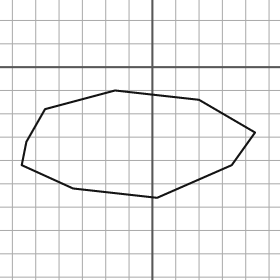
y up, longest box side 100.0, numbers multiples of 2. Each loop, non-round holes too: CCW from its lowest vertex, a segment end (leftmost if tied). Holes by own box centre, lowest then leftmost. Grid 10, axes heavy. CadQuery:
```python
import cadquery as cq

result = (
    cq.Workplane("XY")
    .moveTo(2.0, -56.0)
    .lineTo(34.0, -42.0)
    .lineTo(44.0, -28.0)
    .lineTo(20.0, -14.0)
    .lineTo(-16.0, -10.0)
    .lineTo(-46.0, -18.0)
    .lineTo(-54.0, -32.0)
    .lineTo(-56.0, -42.0)
    .lineTo(-34.0, -52.0)
    .close()
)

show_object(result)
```